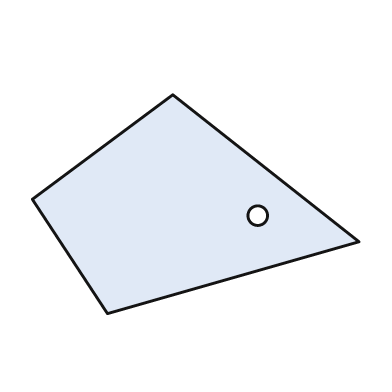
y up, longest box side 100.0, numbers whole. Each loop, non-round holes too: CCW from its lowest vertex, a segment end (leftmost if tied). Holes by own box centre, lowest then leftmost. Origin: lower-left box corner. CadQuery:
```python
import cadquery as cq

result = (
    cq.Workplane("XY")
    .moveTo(23.0, 0.0)
    .lineTo(100.0, 22.0)
    .lineTo(43.0, 67.0)
    .lineTo(0.0, 35.0)
    .close()
    .moveTo(69.0, 30.0)
    .circle(3.0)
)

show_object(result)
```